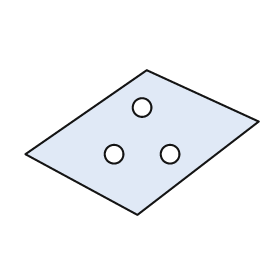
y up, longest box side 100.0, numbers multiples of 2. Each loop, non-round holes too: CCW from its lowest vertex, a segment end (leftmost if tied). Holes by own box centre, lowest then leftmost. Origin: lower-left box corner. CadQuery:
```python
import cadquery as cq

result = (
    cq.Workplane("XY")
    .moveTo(48.0, 0.0)
    .lineTo(100.0, 40.0)
    .lineTo(52.0, 62.0)
    .lineTo(0.0, 26.0)
    .close()
    .moveTo(38.0, 26.0)
    .circle(4.0)
    .moveTo(62.0, 26.0)
    .circle(4.0)
    .moveTo(50.0, 46.0)
    .circle(4.0)
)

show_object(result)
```